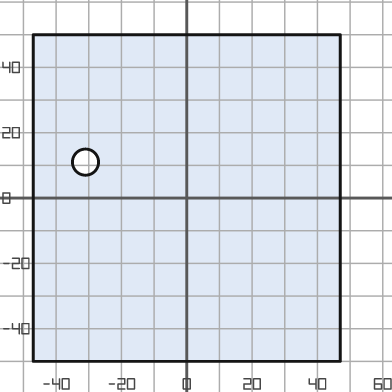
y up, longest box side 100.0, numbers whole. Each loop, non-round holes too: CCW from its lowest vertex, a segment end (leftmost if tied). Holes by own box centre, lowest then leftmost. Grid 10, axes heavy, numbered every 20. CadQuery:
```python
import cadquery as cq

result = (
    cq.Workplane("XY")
    .moveTo(-47.0, -50.0)
    .lineTo(47.0, -50.0)
    .lineTo(47.0, 50.0)
    .lineTo(-47.0, 50.0)
    .close()
    .moveTo(-31.0, 11.0)
    .circle(4.0)
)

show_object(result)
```